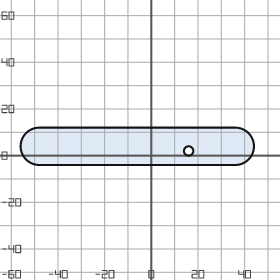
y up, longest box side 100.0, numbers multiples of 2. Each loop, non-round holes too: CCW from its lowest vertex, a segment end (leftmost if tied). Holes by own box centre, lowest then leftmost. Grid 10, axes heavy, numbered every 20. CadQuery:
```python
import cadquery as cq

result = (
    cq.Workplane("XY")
    .moveTo(-48.0, -4.0)
    .lineTo(36.0, -4.0)
    .threePointArc((44.0, 4.0), (36.0, 12.0))
    .lineTo(-48.0, 12.0)
    .threePointArc((-56.0, 4.0), (-48.0, -4.0))
    .close()
    .moveTo(16.0, 2.0)
    .circle(2.0)
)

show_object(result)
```